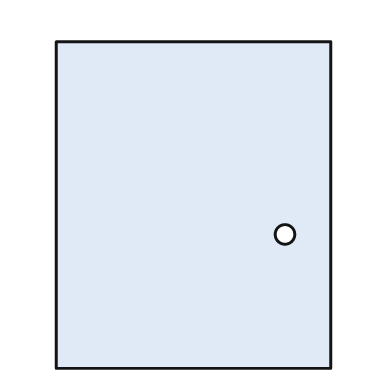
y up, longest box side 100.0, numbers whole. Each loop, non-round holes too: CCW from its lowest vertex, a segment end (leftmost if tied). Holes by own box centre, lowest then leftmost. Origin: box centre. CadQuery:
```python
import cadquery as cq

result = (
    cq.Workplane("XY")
    .moveTo(-42.0, -50.0)
    .lineTo(42.0, -50.0)
    .lineTo(42.0, 50.0)
    .lineTo(-42.0, 50.0)
    .close()
    .moveTo(28.0, -9.0)
    .circle(3.0)
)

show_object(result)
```